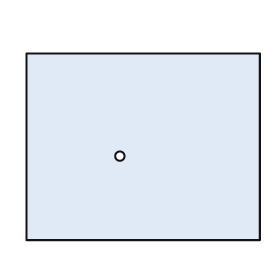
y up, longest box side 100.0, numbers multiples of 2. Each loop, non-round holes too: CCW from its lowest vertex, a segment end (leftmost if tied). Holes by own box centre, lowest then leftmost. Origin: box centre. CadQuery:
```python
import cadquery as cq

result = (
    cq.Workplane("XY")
    .moveTo(-50.0, -40.0)
    .lineTo(50.0, -40.0)
    .lineTo(50.0, 40.0)
    .lineTo(-50.0, 40.0)
    .close()
    .moveTo(-10.0, -4.0)
    .circle(2.0)
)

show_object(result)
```